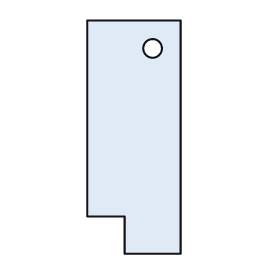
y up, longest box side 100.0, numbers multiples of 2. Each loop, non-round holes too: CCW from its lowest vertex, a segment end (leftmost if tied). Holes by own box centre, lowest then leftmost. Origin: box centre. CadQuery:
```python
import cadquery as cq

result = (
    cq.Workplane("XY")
    .moveTo(-4.0, -50.0)
    .lineTo(20.0, -50.0)
    .lineTo(20.0, 50.0)
    .lineTo(-20.0, 50.0)
    .lineTo(-20.0, -34.0)
    .lineTo(-4.0, -34.0)
    .close()
    .moveTo(8.0, 38.0)
    .circle(4.0)
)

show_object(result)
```